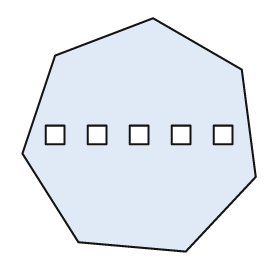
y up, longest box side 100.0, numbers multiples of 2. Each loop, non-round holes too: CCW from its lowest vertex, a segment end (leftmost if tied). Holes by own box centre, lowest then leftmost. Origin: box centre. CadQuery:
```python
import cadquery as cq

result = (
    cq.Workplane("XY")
    .moveTo(20.0, -50.0)
    .lineTo(50.0, -18.0)
    .lineTo(44.0, 28.0)
    .lineTo(6.0, 50.0)
    .lineTo(-36.0, 34.0)
    .lineTo(-50.0, -8.0)
    .lineTo(-26.0, -46.0)
    .close()
    .moveTo(-40.0, -4.0)
    .lineTo(-32.0, -4.0)
    .lineTo(-32.0, 4.0)
    .lineTo(-40.0, 4.0)
    .close()
    .moveTo(-22.0, -4.0)
    .lineTo(-14.0, -4.0)
    .lineTo(-14.0, 4.0)
    .lineTo(-22.0, 4.0)
    .close()
    .moveTo(-4.0, -4.0)
    .lineTo(4.0, -4.0)
    .lineTo(4.0, 4.0)
    .lineTo(-4.0, 4.0)
    .close()
    .moveTo(14.0, -4.0)
    .lineTo(22.0, -4.0)
    .lineTo(22.0, 4.0)
    .lineTo(14.0, 4.0)
    .close()
    .moveTo(32.0, -4.0)
    .lineTo(40.0, -4.0)
    .lineTo(40.0, 4.0)
    .lineTo(32.0, 4.0)
    .close()
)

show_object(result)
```